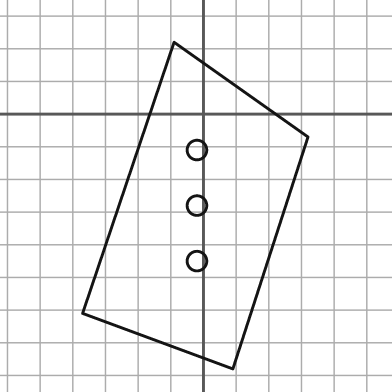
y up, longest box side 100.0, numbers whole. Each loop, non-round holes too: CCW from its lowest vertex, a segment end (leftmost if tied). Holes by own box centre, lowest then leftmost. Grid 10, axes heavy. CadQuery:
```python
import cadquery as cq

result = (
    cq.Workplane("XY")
    .moveTo(9.0, -78.0)
    .lineTo(32.0, -7.0)
    .lineTo(-9.0, 22.0)
    .lineTo(-37.0, -61.0)
    .close()
    .moveTo(-2.0, -45.0)
    .circle(3.0)
    .moveTo(-2.0, -28.0)
    .circle(3.0)
    .moveTo(-2.0, -11.0)
    .circle(3.0)
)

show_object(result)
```